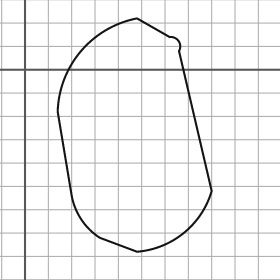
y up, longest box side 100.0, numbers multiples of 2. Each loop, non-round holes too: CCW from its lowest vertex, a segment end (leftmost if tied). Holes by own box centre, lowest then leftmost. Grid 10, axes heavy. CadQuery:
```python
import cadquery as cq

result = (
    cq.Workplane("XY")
    .moveTo(48.0, -78.0)
    .threePointArc((68.0, -70.0), (80.0, -52.0))
    .lineTo(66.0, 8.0)
    .threePointArc((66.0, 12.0), (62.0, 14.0))
    .lineTo(48.0, 22.0)
    .threePointArc((24.0, 8.0), (14.0, -18.0))
    .lineTo(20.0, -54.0)
    .threePointArc((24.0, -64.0), (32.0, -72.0))
    .close()
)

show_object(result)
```